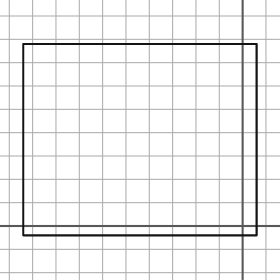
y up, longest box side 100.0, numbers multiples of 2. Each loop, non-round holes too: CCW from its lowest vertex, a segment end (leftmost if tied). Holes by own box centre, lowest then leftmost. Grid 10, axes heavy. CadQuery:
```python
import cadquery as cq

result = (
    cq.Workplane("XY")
    .moveTo(-94.0, -4.0)
    .lineTo(6.0, -4.0)
    .lineTo(6.0, 78.0)
    .lineTo(-94.0, 78.0)
    .close()
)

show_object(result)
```